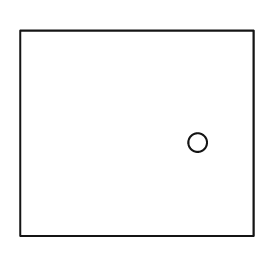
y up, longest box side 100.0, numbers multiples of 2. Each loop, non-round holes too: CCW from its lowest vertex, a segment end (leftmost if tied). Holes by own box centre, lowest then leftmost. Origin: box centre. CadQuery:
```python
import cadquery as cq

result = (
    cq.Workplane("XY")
    .moveTo(-50.0, -44.0)
    .lineTo(50.0, -44.0)
    .lineTo(50.0, 44.0)
    .lineTo(-50.0, 44.0)
    .close()
    .moveTo(26.0, -4.0)
    .circle(4.0)
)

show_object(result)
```